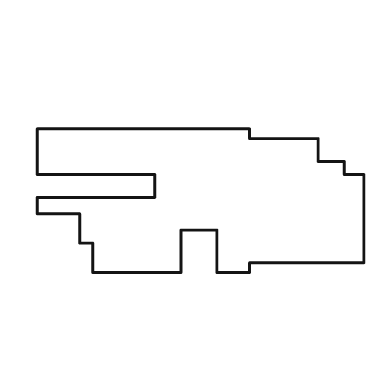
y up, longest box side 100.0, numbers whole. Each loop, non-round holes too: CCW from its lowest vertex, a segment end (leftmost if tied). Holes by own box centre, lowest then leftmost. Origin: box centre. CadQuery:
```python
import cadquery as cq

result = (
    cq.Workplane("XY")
    .moveTo(-33.0, -22.0)
    .lineTo(-6.0, -22.0)
    .lineTo(-6.0, -9.0)
    .lineTo(5.0, -9.0)
    .lineTo(5.0, -22.0)
    .lineTo(15.0, -22.0)
    .lineTo(15.0, -19.0)
    .lineTo(50.0, -19.0)
    .lineTo(50.0, 8.0)
    .lineTo(44.0, 8.0)
    .lineTo(44.0, 12.0)
    .lineTo(36.0, 12.0)
    .lineTo(36.0, 19.0)
    .lineTo(15.0, 19.0)
    .lineTo(15.0, 22.0)
    .lineTo(-50.0, 22.0)
    .lineTo(-50.0, 8.0)
    .lineTo(-14.0, 8.0)
    .lineTo(-14.0, 1.0)
    .lineTo(-50.0, 1.0)
    .lineTo(-50.0, -4.0)
    .lineTo(-37.0, -4.0)
    .lineTo(-37.0, -13.0)
    .lineTo(-33.0, -13.0)
    .close()
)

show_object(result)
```